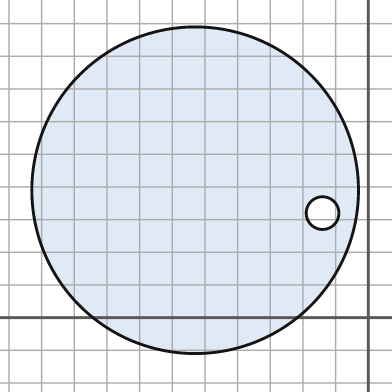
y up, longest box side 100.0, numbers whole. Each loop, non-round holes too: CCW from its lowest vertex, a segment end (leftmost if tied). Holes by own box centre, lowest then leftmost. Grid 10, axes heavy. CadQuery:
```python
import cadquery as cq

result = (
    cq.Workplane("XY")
    .moveTo(-53.0, 39.0)
    .circle(50.0)
    .moveTo(-14.0, 32.0)
    .circle(5.0)
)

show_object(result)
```